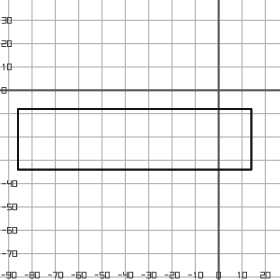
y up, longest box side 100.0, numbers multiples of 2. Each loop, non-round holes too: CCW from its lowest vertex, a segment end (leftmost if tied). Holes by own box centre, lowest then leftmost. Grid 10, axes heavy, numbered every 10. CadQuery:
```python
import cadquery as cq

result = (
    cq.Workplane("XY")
    .moveTo(-86.0, -34.0)
    .lineTo(14.0, -34.0)
    .lineTo(14.0, -8.0)
    .lineTo(-86.0, -8.0)
    .close()
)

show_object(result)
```